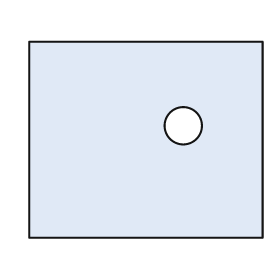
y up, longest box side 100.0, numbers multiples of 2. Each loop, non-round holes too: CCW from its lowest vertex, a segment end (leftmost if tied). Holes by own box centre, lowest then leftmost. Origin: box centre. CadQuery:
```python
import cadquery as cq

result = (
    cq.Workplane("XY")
    .moveTo(-50.0, -42.0)
    .lineTo(50.0, -42.0)
    .lineTo(50.0, 42.0)
    .lineTo(-50.0, 42.0)
    .close()
    .moveTo(16.0, 6.0)
    .circle(8.0)
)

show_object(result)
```